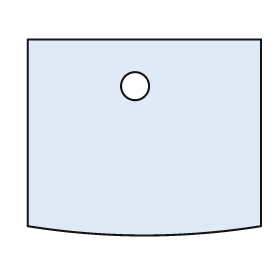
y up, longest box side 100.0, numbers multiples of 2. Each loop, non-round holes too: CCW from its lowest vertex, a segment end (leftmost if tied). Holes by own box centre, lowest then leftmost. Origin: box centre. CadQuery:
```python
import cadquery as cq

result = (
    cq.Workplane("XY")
    .moveTo(-50.0, -38.0)
    .threePointArc((0.0, -42.0), (50.0, -38.0))
    .lineTo(50.0, 42.0)
    .lineTo(-50.0, 42.0)
    .close()
    .moveTo(-4.0, 22.0)
    .circle(6.0)
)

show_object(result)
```